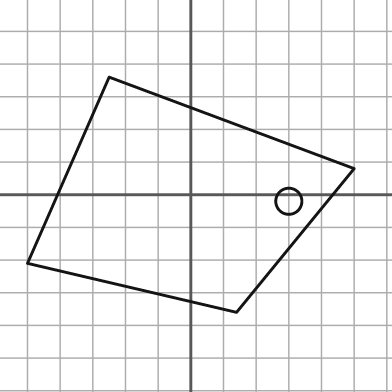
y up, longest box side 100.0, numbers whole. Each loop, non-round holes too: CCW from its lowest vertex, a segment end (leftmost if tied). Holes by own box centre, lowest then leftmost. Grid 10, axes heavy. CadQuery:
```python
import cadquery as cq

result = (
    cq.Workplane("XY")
    .moveTo(14.0, -36.0)
    .lineTo(50.0, 8.0)
    .lineTo(-25.0, 36.0)
    .lineTo(-50.0, -21.0)
    .close()
    .moveTo(30.0, -2.0)
    .circle(4.0)
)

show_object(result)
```